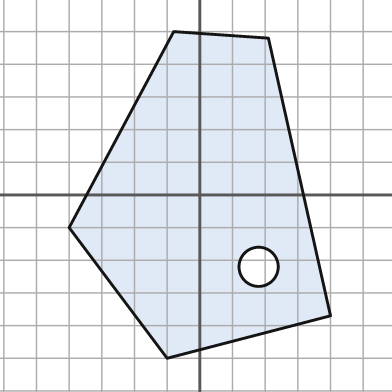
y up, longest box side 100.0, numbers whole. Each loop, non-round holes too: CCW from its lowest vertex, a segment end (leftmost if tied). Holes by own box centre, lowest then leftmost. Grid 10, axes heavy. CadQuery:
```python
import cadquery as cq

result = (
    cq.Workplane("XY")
    .moveTo(-10.0, -50.0)
    .lineTo(40.0, -37.0)
    .lineTo(21.0, 48.0)
    .lineTo(-8.0, 50.0)
    .lineTo(-40.0, -10.0)
    .close()
    .moveTo(18.0, -22.0)
    .circle(6.0)
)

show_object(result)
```